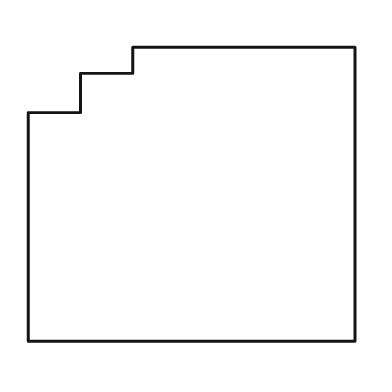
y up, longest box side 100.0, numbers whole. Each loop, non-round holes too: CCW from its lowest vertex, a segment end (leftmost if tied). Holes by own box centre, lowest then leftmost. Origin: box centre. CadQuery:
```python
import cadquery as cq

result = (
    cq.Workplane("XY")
    .moveTo(-50.0, -45.0)
    .lineTo(50.0, -45.0)
    .lineTo(50.0, 45.0)
    .lineTo(-18.0, 45.0)
    .lineTo(-18.0, 37.0)
    .lineTo(-34.0, 37.0)
    .lineTo(-34.0, 25.0)
    .lineTo(-50.0, 25.0)
    .close()
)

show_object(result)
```